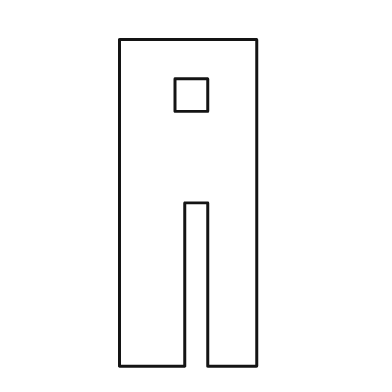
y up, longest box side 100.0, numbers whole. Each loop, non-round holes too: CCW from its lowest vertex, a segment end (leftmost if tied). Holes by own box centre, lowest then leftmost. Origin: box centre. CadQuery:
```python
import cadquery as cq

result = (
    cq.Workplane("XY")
    .moveTo(-21.0, -50.0)
    .lineTo(-1.0, -50.0)
    .lineTo(-1.0, 0.0)
    .lineTo(6.0, 0.0)
    .lineTo(6.0, -50.0)
    .lineTo(21.0, -50.0)
    .lineTo(21.0, 50.0)
    .lineTo(-21.0, 50.0)
    .close()
    .moveTo(-4.0, 28.0)
    .lineTo(6.0, 28.0)
    .lineTo(6.0, 38.0)
    .lineTo(-4.0, 38.0)
    .close()
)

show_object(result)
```